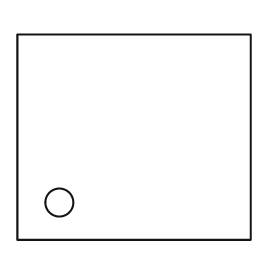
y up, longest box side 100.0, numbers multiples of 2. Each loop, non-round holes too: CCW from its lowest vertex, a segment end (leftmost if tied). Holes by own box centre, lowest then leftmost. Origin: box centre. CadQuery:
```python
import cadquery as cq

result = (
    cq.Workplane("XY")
    .moveTo(-50.0, -44.0)
    .lineTo(50.0, -44.0)
    .lineTo(50.0, 44.0)
    .lineTo(-50.0, 44.0)
    .close()
    .moveTo(-32.0, -28.0)
    .circle(6.0)
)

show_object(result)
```